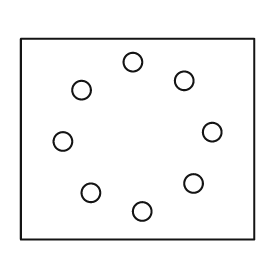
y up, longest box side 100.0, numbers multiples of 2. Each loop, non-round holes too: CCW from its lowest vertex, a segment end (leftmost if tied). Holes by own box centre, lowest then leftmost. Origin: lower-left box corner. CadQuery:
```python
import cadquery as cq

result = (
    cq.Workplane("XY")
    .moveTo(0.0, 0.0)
    .lineTo(100.0, 0.0)
    .lineTo(100.0, 86.0)
    .lineTo(0.0, 86.0)
    .close()
    .moveTo(52.0, 12.0)
    .circle(4.0)
    .moveTo(30.0, 20.0)
    .circle(4.0)
    .moveTo(74.0, 24.0)
    .circle(4.0)
    .moveTo(18.0, 42.0)
    .circle(4.0)
    .moveTo(82.0, 46.0)
    .circle(4.0)
    .moveTo(26.0, 64.0)
    .circle(4.0)
    .moveTo(70.0, 68.0)
    .circle(4.0)
    .moveTo(48.0, 76.0)
    .circle(4.0)
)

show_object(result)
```